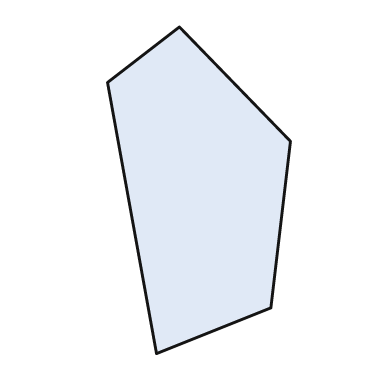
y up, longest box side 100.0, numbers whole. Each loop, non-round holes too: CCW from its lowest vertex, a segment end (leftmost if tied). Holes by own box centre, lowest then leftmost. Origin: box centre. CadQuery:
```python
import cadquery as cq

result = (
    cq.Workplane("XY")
    .moveTo(-13.0, -50.0)
    .lineTo(22.0, -36.0)
    .lineTo(28.0, 15.0)
    .lineTo(-6.0, 50.0)
    .lineTo(-28.0, 33.0)
    .close()
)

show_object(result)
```